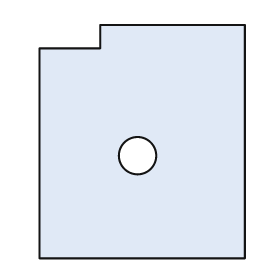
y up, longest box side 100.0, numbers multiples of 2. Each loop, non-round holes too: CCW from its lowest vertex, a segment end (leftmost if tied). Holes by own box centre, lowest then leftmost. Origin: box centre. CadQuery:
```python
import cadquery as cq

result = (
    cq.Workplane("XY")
    .moveTo(-44.0, -50.0)
    .lineTo(44.0, -50.0)
    .lineTo(44.0, 50.0)
    .lineTo(-18.0, 50.0)
    .lineTo(-18.0, 40.0)
    .lineTo(-44.0, 40.0)
    .close()
    .moveTo(-2.0, -6.0)
    .circle(8.0)
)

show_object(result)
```